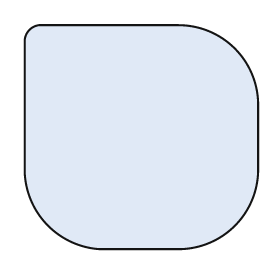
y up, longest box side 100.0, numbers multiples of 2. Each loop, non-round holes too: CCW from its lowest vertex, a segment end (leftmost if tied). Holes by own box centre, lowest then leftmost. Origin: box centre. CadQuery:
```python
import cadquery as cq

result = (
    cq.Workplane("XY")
    .moveTo(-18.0, -48.0)
    .lineTo(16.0, -48.0)
    .threePointArc((40.0, -38.0), (50.0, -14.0))
    .lineTo(50.0, 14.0)
    .threePointArc((40.0, 38.0), (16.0, 48.0))
    .lineTo(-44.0, 48.0)
    .threePointArc((-48.0, 46.0), (-50.0, 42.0))
    .lineTo(-50.0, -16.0)
    .threePointArc((-40.0, -38.0), (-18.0, -48.0))
    .close()
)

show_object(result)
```